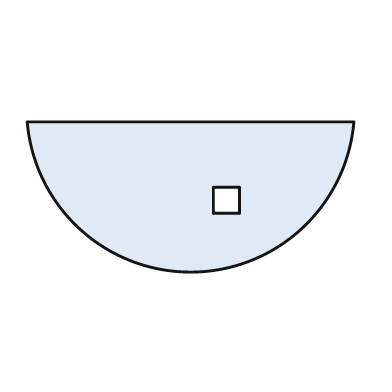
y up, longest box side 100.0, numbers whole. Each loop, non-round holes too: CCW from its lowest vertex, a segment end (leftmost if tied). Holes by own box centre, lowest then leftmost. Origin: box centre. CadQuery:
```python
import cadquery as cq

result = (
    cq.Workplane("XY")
    .moveTo(-50.0, 23.0)
    .threePointArc((0.0, -23.0), (50.0, 23.0))
    .close()
    .moveTo(7.0, -5.0)
    .lineTo(15.0, -5.0)
    .lineTo(15.0, 3.0)
    .lineTo(7.0, 3.0)
    .close()
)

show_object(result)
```